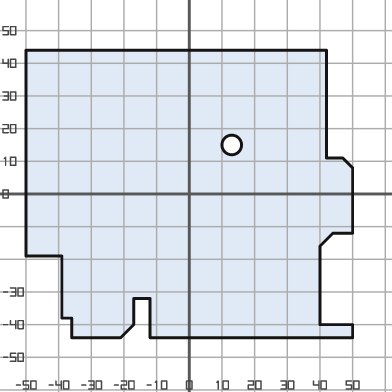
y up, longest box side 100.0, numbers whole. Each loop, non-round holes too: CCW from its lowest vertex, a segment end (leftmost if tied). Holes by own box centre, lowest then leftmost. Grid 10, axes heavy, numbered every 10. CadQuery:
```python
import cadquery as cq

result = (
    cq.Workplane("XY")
    .moveTo(-36.0, -44.0)
    .lineTo(-21.0, -44.0)
    .lineTo(-17.0, -40.0)
    .lineTo(-17.0, -32.0)
    .lineTo(-12.0, -32.0)
    .lineTo(-12.0, -44.0)
    .lineTo(50.0, -44.0)
    .lineTo(50.0, -40.0)
    .lineTo(40.0, -40.0)
    .lineTo(40.0, -16.0)
    .lineTo(44.0, -12.0)
    .lineTo(50.0, -12.0)
    .lineTo(50.0, 8.0)
    .lineTo(47.0, 11.0)
    .lineTo(42.0, 11.0)
    .lineTo(42.0, 44.0)
    .lineTo(-50.0, 44.0)
    .lineTo(-50.0, -19.0)
    .lineTo(-39.0, -19.0)
    .lineTo(-39.0, -38.0)
    .lineTo(-36.0, -38.0)
    .close()
    .moveTo(13.0, 15.0)
    .circle(3.0)
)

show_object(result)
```